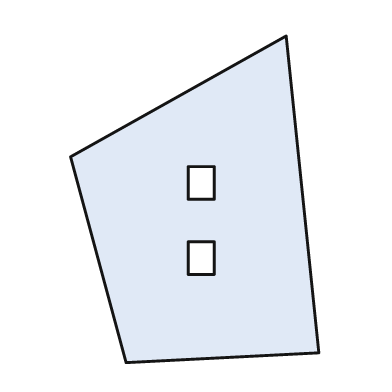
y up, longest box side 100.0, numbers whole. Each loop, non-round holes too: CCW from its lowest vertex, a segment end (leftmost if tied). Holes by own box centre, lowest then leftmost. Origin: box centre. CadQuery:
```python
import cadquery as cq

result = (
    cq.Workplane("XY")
    .moveTo(-21.0, -50.0)
    .lineTo(38.0, -47.0)
    .lineTo(28.0, 50.0)
    .lineTo(-38.0, 13.0)
    .close()
    .moveTo(-2.0, -23.0)
    .lineTo(6.0, -23.0)
    .lineTo(6.0, -13.0)
    .lineTo(-2.0, -13.0)
    .close()
    .moveTo(-2.0, 0.0)
    .lineTo(6.0, 0.0)
    .lineTo(6.0, 10.0)
    .lineTo(-2.0, 10.0)
    .close()
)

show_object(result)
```